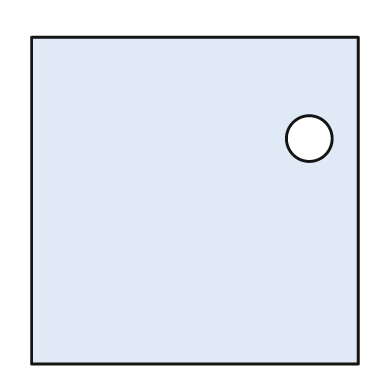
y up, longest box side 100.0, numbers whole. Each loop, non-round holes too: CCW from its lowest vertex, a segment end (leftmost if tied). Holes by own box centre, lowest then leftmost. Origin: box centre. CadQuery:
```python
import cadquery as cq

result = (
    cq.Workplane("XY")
    .moveTo(-50.0, -50.0)
    .lineTo(50.0, -50.0)
    .lineTo(50.0, 50.0)
    .lineTo(-50.0, 50.0)
    .close()
    .moveTo(35.0, 19.0)
    .circle(7.0)
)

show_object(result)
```